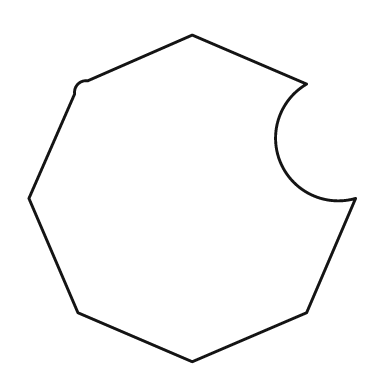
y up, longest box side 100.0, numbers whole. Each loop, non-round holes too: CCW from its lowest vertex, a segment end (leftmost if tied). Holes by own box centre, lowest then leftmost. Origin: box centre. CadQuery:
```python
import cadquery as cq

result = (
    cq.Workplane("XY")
    .moveTo(0.0, -50.0)
    .lineTo(35.0, -35.0)
    .lineTo(50.0, 0.0)
    .threePointArc((27.0, 11.0), (35.0, 35.0))
    .lineTo(0.0, 50.0)
    .lineTo(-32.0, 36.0)
    .threePointArc((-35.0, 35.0), (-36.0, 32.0))
    .lineTo(-50.0, 0.0)
    .lineTo(-35.0, -35.0)
    .close()
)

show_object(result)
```